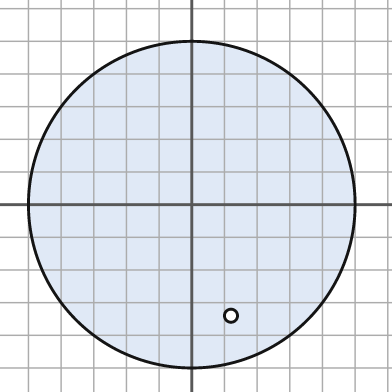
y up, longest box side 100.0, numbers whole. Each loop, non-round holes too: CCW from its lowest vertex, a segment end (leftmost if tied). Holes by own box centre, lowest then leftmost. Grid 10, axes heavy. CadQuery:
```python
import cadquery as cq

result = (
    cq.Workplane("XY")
    .moveTo(0.0, 0.0)
    .circle(50.0)
    .moveTo(12.0, -34.0)
    .circle(2.0)
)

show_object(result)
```